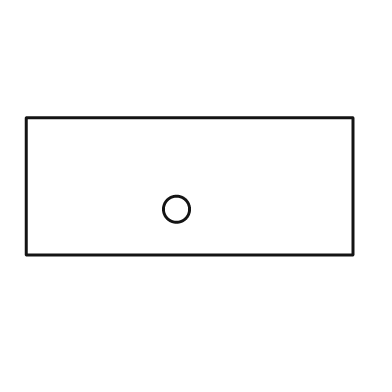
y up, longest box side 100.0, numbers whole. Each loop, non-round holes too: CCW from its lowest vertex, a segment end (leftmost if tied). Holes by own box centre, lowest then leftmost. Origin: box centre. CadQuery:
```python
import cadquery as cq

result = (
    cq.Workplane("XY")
    .moveTo(-50.0, -21.0)
    .lineTo(50.0, -21.0)
    .lineTo(50.0, 21.0)
    .lineTo(-50.0, 21.0)
    .close()
    .moveTo(-4.0, -7.0)
    .circle(4.0)
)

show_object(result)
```